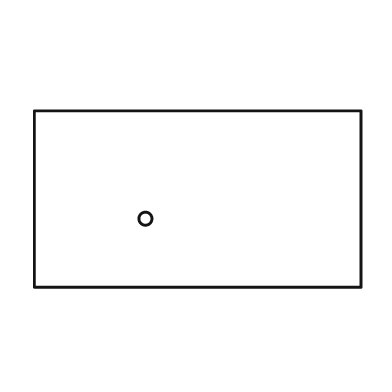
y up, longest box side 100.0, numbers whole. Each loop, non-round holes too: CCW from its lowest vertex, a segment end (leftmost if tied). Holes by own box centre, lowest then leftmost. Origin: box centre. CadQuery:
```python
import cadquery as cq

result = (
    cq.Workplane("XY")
    .moveTo(-50.0, -27.0)
    .lineTo(50.0, -27.0)
    .lineTo(50.0, 27.0)
    .lineTo(-50.0, 27.0)
    .close()
    .moveTo(-16.0, -6.0)
    .circle(2.0)
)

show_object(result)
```